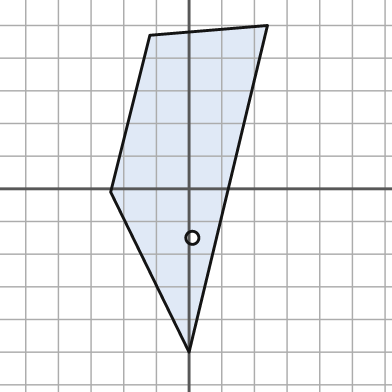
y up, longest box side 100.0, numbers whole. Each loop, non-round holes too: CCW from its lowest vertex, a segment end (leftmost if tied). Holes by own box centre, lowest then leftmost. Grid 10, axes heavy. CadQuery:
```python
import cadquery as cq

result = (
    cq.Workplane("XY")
    .moveTo(0.0, -50.0)
    .lineTo(24.0, 50.0)
    .lineTo(-12.0, 47.0)
    .lineTo(-24.0, -1.0)
    .close()
    .moveTo(1.0, -15.0)
    .circle(2.0)
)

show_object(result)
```